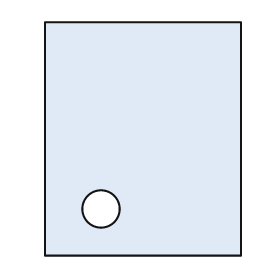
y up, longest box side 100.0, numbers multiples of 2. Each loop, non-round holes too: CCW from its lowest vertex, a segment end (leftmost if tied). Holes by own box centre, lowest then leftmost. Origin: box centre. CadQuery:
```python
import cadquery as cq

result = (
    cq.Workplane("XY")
    .moveTo(-42.0, -50.0)
    .lineTo(42.0, -50.0)
    .lineTo(42.0, 50.0)
    .lineTo(-42.0, 50.0)
    .close()
    .moveTo(-18.0, -30.0)
    .circle(8.0)
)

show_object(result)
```